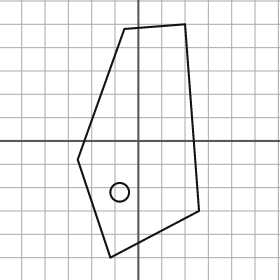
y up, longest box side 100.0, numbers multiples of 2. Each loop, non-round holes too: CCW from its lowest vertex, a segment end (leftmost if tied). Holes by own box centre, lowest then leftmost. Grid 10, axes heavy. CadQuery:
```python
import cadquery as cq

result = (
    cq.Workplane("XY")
    .moveTo(-12.0, -50.0)
    .lineTo(26.0, -30.0)
    .lineTo(20.0, 50.0)
    .lineTo(-6.0, 48.0)
    .lineTo(-26.0, -8.0)
    .close()
    .moveTo(-8.0, -22.0)
    .circle(4.0)
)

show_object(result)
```